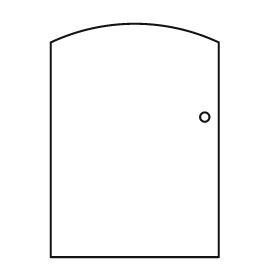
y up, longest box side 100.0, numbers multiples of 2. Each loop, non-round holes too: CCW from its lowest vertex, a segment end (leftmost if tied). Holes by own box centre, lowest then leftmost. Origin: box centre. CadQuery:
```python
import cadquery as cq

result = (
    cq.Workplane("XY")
    .moveTo(-36.0, -50.0)
    .lineTo(36.0, -50.0)
    .lineTo(36.0, 42.0)
    .threePointArc((0.0, 50.0), (-36.0, 42.0))
    .close()
    .moveTo(30.0, 10.0)
    .circle(2.0)
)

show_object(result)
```